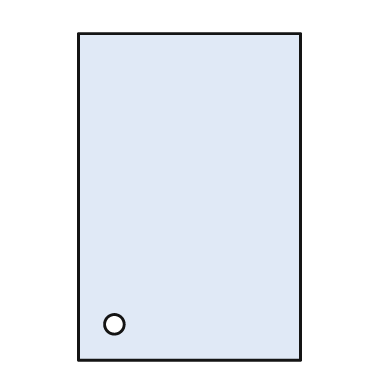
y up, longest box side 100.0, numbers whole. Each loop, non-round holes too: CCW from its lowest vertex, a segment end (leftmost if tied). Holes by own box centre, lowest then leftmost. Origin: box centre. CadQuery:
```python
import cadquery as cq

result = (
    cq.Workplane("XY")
    .moveTo(-34.0, -50.0)
    .lineTo(34.0, -50.0)
    .lineTo(34.0, 50.0)
    .lineTo(-34.0, 50.0)
    .close()
    .moveTo(-23.0, -39.0)
    .circle(3.0)
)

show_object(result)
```